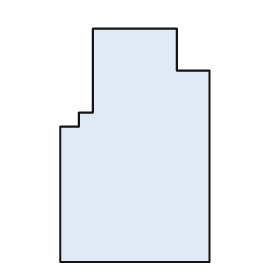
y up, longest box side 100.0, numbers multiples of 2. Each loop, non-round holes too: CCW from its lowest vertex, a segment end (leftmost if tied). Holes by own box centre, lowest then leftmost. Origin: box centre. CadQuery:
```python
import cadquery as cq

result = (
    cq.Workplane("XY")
    .moveTo(-32.0, -50.0)
    .lineTo(32.0, -50.0)
    .lineTo(32.0, 32.0)
    .lineTo(18.0, 32.0)
    .lineTo(18.0, 50.0)
    .lineTo(-18.0, 50.0)
    .lineTo(-18.0, 14.0)
    .lineTo(-24.0, 14.0)
    .lineTo(-24.0, 8.0)
    .lineTo(-32.0, 8.0)
    .close()
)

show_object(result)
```